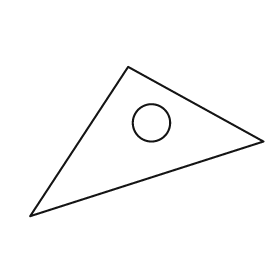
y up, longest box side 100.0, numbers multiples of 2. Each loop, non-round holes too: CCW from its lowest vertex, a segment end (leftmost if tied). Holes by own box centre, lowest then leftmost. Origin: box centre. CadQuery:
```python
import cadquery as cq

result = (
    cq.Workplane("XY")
    .moveTo(-50.0, -32.0)
    .lineTo(50.0, 0.0)
    .lineTo(-8.0, 32.0)
    .close()
    .moveTo(2.0, 8.0)
    .circle(8.0)
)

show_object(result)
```